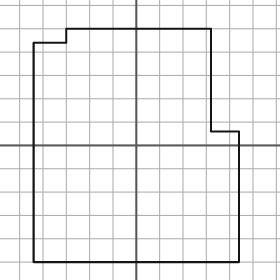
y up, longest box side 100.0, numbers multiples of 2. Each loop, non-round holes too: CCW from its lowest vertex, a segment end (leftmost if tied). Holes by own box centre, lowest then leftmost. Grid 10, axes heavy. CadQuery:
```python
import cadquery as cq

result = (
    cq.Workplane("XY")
    .moveTo(-44.0, -50.0)
    .lineTo(44.0, -50.0)
    .lineTo(44.0, 6.0)
    .lineTo(32.0, 6.0)
    .lineTo(32.0, 50.0)
    .lineTo(-30.0, 50.0)
    .lineTo(-30.0, 44.0)
    .lineTo(-44.0, 44.0)
    .close()
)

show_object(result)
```